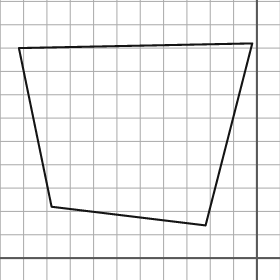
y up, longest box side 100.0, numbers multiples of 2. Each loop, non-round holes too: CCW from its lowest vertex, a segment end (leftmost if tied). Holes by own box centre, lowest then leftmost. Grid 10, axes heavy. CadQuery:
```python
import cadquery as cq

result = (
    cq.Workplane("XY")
    .moveTo(-22.0, 14.0)
    .lineTo(-2.0, 92.0)
    .lineTo(-102.0, 90.0)
    .lineTo(-88.0, 22.0)
    .close()
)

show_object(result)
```